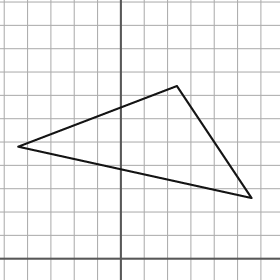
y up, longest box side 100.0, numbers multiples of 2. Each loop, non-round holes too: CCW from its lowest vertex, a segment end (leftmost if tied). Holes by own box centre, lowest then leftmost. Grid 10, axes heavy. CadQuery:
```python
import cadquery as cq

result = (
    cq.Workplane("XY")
    .moveTo(56.0, 26.0)
    .lineTo(24.0, 74.0)
    .lineTo(-44.0, 48.0)
    .close()
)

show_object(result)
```